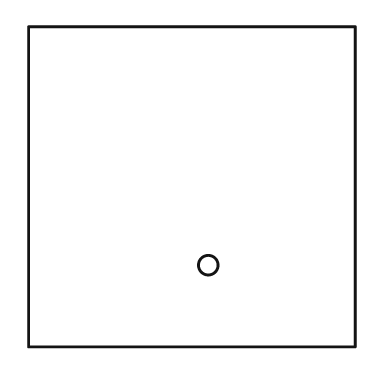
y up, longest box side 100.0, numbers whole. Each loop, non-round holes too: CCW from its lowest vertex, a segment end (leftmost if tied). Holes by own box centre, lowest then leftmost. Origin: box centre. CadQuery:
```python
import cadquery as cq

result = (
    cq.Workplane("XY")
    .moveTo(-50.0, -49.0)
    .lineTo(50.0, -49.0)
    .lineTo(50.0, 49.0)
    .lineTo(-50.0, 49.0)
    .close()
    .moveTo(5.0, -24.0)
    .circle(3.0)
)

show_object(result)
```